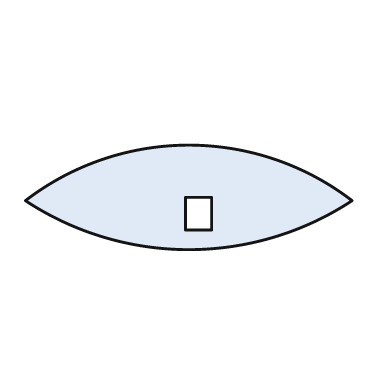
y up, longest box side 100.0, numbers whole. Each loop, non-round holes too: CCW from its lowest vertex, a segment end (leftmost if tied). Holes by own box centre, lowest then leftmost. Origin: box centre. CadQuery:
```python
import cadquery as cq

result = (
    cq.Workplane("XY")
    .moveTo(-50.0, -1.0)
    .threePointArc((0.0, -16.0), (50.0, -1.0))
    .threePointArc((0.0, 16.0), (-50.0, -1.0))
    .close()
    .moveTo(-1.0, -10.0)
    .lineTo(7.0, -10.0)
    .lineTo(7.0, 0.0)
    .lineTo(-1.0, 0.0)
    .close()
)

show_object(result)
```